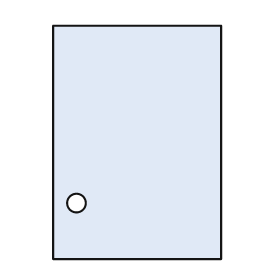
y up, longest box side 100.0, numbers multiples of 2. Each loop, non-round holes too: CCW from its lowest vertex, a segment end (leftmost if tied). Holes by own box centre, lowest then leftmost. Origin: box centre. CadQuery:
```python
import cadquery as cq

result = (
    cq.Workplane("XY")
    .moveTo(-36.0, -50.0)
    .lineTo(36.0, -50.0)
    .lineTo(36.0, 50.0)
    .lineTo(-36.0, 50.0)
    .close()
    .moveTo(-26.0, -26.0)
    .circle(4.0)
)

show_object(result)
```